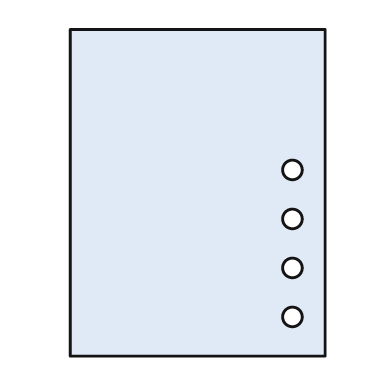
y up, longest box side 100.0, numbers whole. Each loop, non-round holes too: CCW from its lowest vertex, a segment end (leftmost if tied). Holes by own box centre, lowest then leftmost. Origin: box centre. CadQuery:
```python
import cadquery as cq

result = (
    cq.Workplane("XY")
    .moveTo(-39.0, -50.0)
    .lineTo(39.0, -50.0)
    .lineTo(39.0, 50.0)
    .lineTo(-39.0, 50.0)
    .close()
    .moveTo(29.0, -38.0)
    .circle(3.0)
    .moveTo(29.0, -23.0)
    .circle(3.0)
    .moveTo(29.0, -8.0)
    .circle(3.0)
    .moveTo(29.0, 7.0)
    .circle(3.0)
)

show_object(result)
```